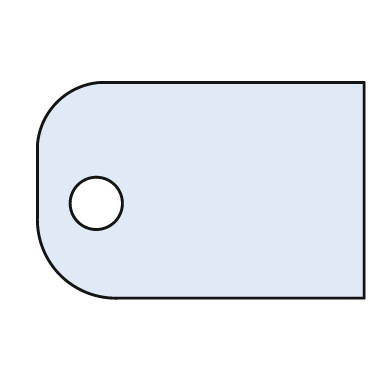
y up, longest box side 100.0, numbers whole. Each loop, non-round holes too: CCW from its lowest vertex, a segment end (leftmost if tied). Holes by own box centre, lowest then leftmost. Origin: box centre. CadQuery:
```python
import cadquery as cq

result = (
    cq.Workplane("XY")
    .moveTo(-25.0, -33.0)
    .lineTo(50.0, -33.0)
    .lineTo(50.0, 33.0)
    .lineTo(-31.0, 33.0)
    .threePointArc((-44.0, 27.0), (-50.0, 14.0))
    .lineTo(-50.0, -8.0)
    .threePointArc((-43.0, -26.0), (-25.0, -33.0))
    .close()
    .moveTo(-32.0, -4.0)
    .circle(8.0)
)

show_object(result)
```